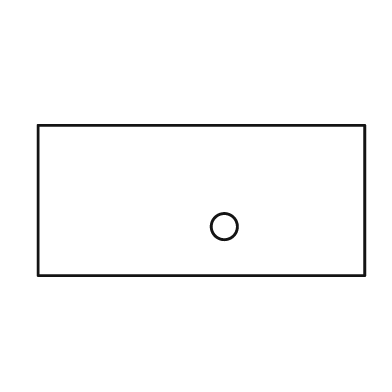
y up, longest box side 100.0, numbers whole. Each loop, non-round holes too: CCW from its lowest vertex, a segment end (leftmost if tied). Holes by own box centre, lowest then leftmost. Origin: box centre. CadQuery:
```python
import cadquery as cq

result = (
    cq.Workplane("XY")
    .moveTo(-50.0, -23.0)
    .lineTo(50.0, -23.0)
    .lineTo(50.0, 23.0)
    .lineTo(-50.0, 23.0)
    .close()
    .moveTo(7.0, -8.0)
    .circle(4.0)
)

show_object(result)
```